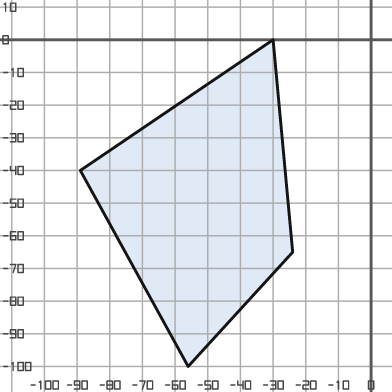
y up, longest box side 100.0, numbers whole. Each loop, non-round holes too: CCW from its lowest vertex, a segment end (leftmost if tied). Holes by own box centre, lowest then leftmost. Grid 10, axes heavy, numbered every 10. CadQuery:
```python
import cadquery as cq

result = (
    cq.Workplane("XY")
    .moveTo(-56.0, -100.0)
    .lineTo(-24.0, -65.0)
    .lineTo(-30.0, 0.0)
    .lineTo(-89.0, -40.0)
    .close()
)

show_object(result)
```